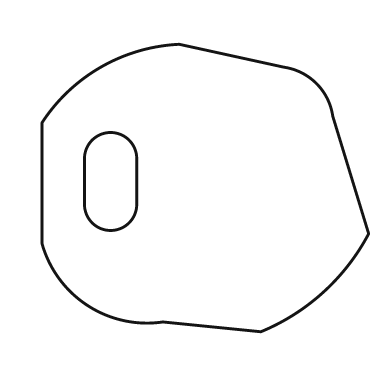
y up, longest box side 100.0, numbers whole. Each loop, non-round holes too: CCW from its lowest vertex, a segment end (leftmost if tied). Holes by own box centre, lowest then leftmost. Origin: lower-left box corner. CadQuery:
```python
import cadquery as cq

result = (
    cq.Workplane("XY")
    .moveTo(67.0, 0.0)
    .threePointArc((86.0, 12.0), (100.0, 30.0))
    .lineTo(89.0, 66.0)
    .threePointArc((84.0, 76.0), (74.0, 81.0))
    .lineTo(42.0, 88.0)
    .threePointArc((18.0, 81.0), (0.0, 64.0))
    .lineTo(0.0, 27.0)
    .threePointArc((14.0, 8.0), (37.0, 3.0))
    .close()
    .moveTo(13.0, 39.0)
    .threePointArc((21.0, 31.0), (29.0, 39.0))
    .lineTo(29.0, 53.0)
    .threePointArc((21.0, 61.0), (13.0, 53.0))
    .close()
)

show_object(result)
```